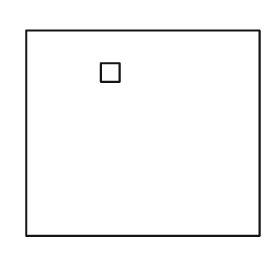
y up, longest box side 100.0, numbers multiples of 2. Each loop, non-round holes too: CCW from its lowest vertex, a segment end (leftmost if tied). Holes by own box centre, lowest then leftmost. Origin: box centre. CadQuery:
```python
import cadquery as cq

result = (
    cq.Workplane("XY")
    .moveTo(-50.0, -44.0)
    .lineTo(50.0, -44.0)
    .lineTo(50.0, 44.0)
    .lineTo(-50.0, 44.0)
    .close()
    .moveTo(-18.0, 22.0)
    .lineTo(-10.0, 22.0)
    .lineTo(-10.0, 30.0)
    .lineTo(-18.0, 30.0)
    .close()
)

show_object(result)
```